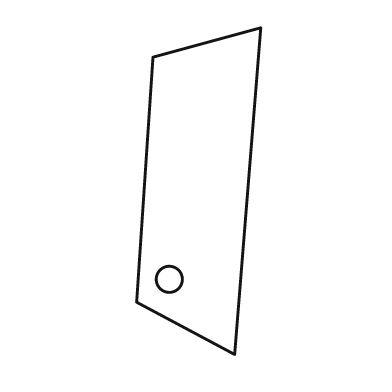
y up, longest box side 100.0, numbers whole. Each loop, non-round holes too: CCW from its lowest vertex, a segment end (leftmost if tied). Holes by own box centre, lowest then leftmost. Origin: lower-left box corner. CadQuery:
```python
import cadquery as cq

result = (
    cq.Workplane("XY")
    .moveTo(30.0, 0.0)
    .lineTo(38.0, 100.0)
    .lineTo(5.0, 91.0)
    .lineTo(0.0, 16.0)
    .close()
    .moveTo(10.0, 23.0)
    .circle(4.0)
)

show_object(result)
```